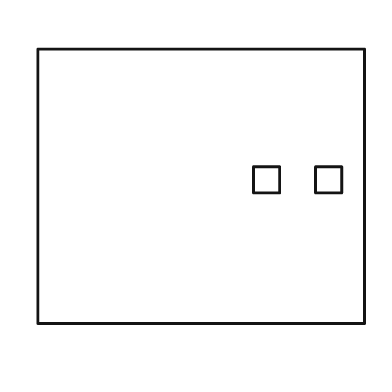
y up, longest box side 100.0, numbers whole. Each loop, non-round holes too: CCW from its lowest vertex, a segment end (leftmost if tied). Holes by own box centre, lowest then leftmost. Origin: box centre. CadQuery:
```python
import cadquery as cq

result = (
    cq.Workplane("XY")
    .moveTo(-50.0, -42.0)
    .lineTo(50.0, -42.0)
    .lineTo(50.0, 42.0)
    .lineTo(-50.0, 42.0)
    .close()
    .moveTo(16.0, -2.0)
    .lineTo(24.0, -2.0)
    .lineTo(24.0, 6.0)
    .lineTo(16.0, 6.0)
    .close()
    .moveTo(35.0, -2.0)
    .lineTo(43.0, -2.0)
    .lineTo(43.0, 6.0)
    .lineTo(35.0, 6.0)
    .close()
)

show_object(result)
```